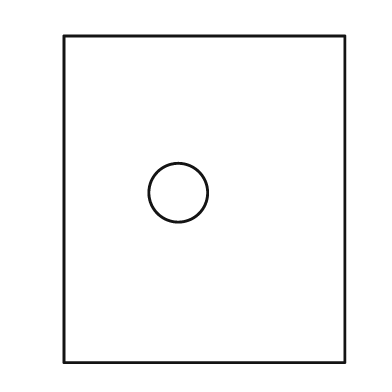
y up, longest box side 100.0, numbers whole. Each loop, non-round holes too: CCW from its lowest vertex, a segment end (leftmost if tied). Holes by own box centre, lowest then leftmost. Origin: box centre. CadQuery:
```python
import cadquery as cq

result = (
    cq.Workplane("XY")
    .moveTo(-43.0, -50.0)
    .lineTo(43.0, -50.0)
    .lineTo(43.0, 50.0)
    .lineTo(-43.0, 50.0)
    .close()
    .moveTo(-8.0, 2.0)
    .circle(9.0)
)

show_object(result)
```